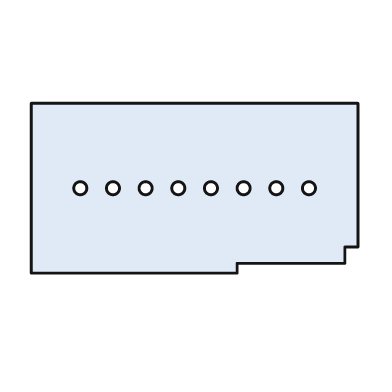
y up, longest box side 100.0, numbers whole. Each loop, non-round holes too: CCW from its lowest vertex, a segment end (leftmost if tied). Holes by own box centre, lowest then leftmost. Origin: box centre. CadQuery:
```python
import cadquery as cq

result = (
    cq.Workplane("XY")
    .moveTo(-50.0, -26.0)
    .lineTo(13.0, -26.0)
    .lineTo(13.0, -23.0)
    .lineTo(46.0, -23.0)
    .lineTo(46.0, -18.0)
    .lineTo(50.0, -18.0)
    .lineTo(50.0, 26.0)
    .lineTo(-50.0, 26.0)
    .close()
    .moveTo(-35.0, 0.0)
    .circle(2.0)
    .moveTo(-25.0, 0.0)
    .circle(2.0)
    .moveTo(-15.0, 0.0)
    .circle(2.0)
    .moveTo(-5.0, 0.0)
    .circle(2.0)
    .moveTo(5.0, 0.0)
    .circle(2.0)
    .moveTo(15.0, 0.0)
    .circle(2.0)
    .moveTo(25.0, 0.0)
    .circle(2.0)
    .moveTo(35.0, 0.0)
    .circle(2.0)
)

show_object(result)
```